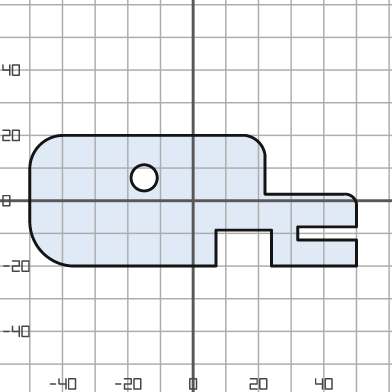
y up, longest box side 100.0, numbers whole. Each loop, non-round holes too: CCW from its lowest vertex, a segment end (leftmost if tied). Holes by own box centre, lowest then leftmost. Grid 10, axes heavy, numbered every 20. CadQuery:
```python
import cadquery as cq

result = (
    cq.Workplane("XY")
    .moveTo(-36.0, -20.0)
    .lineTo(7.0, -20.0)
    .lineTo(7.0, -9.0)
    .lineTo(24.0, -9.0)
    .lineTo(24.0, -20.0)
    .lineTo(50.0, -20.0)
    .lineTo(50.0, -12.0)
    .lineTo(32.0, -12.0)
    .lineTo(32.0, -8.0)
    .lineTo(50.0, -8.0)
    .lineTo(50.0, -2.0)
    .threePointArc((49.0, 1.0), (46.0, 2.0))
    .lineTo(22.0, 2.0)
    .lineTo(22.0, 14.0)
    .threePointArc((20.0, 18.0), (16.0, 20.0))
    .lineTo(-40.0, 20.0)
    .threePointArc((-47.0, 17.0), (-50.0, 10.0))
    .lineTo(-50.0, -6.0)
    .threePointArc((-46.0, -16.0), (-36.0, -20.0))
    .close()
    .moveTo(-15.0, 7.0)
    .circle(4.0)
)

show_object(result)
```